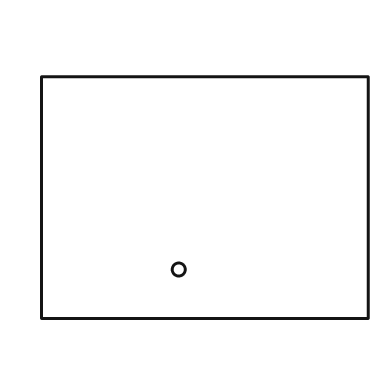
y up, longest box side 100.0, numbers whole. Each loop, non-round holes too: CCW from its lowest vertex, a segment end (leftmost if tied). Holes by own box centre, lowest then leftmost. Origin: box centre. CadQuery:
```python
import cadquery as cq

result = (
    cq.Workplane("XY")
    .moveTo(-50.0, -37.0)
    .lineTo(50.0, -37.0)
    .lineTo(50.0, 37.0)
    .lineTo(-50.0, 37.0)
    .close()
    .moveTo(-8.0, -22.0)
    .circle(2.0)
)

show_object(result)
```